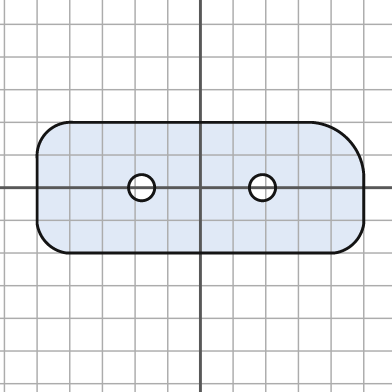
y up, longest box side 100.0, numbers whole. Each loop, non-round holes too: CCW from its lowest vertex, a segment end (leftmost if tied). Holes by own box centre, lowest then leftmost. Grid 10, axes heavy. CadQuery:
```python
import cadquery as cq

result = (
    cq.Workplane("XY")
    .moveTo(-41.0, -20.0)
    .lineTo(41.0, -20.0)
    .threePointArc((47.0, -17.0), (50.0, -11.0))
    .lineTo(50.0, 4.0)
    .threePointArc((45.0, 15.0), (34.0, 20.0))
    .lineTo(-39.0, 20.0)
    .threePointArc((-47.0, 17.0), (-50.0, 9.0))
    .lineTo(-50.0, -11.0)
    .threePointArc((-47.0, -17.0), (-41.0, -20.0))
    .close()
    .moveTo(-18.0, 0.0)
    .circle(4.0)
    .moveTo(19.0, 0.0)
    .circle(4.0)
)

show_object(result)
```